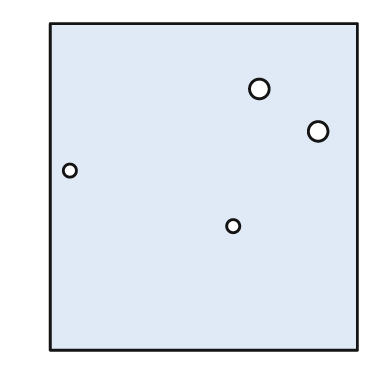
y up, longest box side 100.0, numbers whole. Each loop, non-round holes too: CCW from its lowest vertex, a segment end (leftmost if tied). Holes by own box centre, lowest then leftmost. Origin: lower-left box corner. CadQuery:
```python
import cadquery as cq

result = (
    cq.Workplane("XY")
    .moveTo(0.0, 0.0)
    .lineTo(94.0, 0.0)
    .lineTo(94.0, 100.0)
    .lineTo(0.0, 100.0)
    .close()
    .moveTo(56.0, 38.0)
    .circle(2.0)
    .moveTo(6.0, 55.0)
    .circle(2.0)
    .moveTo(82.0, 67.0)
    .circle(3.0)
    .moveTo(64.0, 80.0)
    .circle(3.0)
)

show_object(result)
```